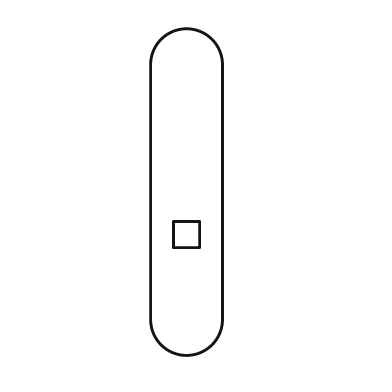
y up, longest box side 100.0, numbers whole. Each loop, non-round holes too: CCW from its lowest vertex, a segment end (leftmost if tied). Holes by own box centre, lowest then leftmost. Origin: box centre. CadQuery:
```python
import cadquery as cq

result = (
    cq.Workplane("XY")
    .moveTo(-11.0, -39.0)
    .threePointArc((0.0, -50.0), (11.0, -39.0))
    .lineTo(11.0, 39.0)
    .threePointArc((0.0, 50.0), (-11.0, 39.0))
    .close()
    .moveTo(-4.0, -17.0)
    .lineTo(4.0, -17.0)
    .lineTo(4.0, -9.0)
    .lineTo(-4.0, -9.0)
    .close()
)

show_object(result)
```